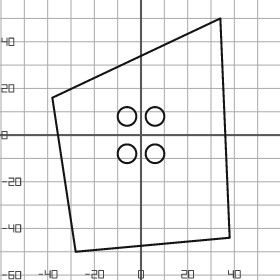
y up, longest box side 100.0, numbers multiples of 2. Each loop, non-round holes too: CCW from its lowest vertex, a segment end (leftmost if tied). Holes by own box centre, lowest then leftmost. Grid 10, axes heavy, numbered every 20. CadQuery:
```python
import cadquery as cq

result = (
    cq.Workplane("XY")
    .moveTo(-28.0, -50.0)
    .lineTo(38.0, -44.0)
    .lineTo(34.0, 50.0)
    .lineTo(-38.0, 16.0)
    .close()
    .moveTo(-6.0, -8.0)
    .circle(4.0)
    .moveTo(6.0, -8.0)
    .circle(4.0)
    .moveTo(-6.0, 8.0)
    .circle(4.0)
    .moveTo(6.0, 8.0)
    .circle(4.0)
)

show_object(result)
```